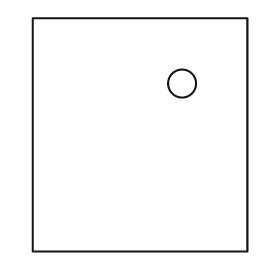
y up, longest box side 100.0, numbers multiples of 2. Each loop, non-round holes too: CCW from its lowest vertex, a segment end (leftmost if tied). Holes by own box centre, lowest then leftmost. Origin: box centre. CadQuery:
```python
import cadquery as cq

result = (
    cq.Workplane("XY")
    .moveTo(-46.0, -50.0)
    .lineTo(46.0, -50.0)
    .lineTo(46.0, 50.0)
    .lineTo(-46.0, 50.0)
    .close()
    .moveTo(18.0, 22.0)
    .circle(6.0)
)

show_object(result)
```